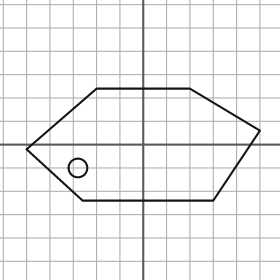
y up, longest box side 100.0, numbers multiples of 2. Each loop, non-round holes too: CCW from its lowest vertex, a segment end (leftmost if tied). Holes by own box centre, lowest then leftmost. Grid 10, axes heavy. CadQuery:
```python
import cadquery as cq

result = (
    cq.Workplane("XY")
    .moveTo(-26.0, -24.0)
    .lineTo(30.0, -24.0)
    .lineTo(50.0, 6.0)
    .lineTo(20.0, 24.0)
    .lineTo(-20.0, 24.0)
    .lineTo(-50.0, -2.0)
    .close()
    .moveTo(-28.0, -10.0)
    .circle(4.0)
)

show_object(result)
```